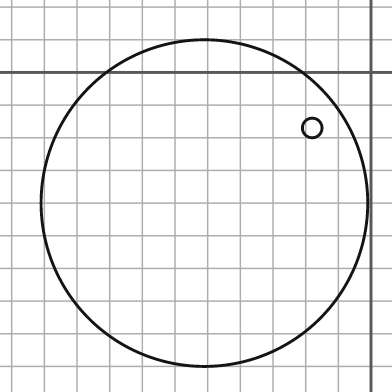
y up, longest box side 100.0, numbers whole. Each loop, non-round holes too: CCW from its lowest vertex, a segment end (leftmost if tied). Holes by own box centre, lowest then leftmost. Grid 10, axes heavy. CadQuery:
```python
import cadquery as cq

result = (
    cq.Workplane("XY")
    .moveTo(-51.0, -40.0)
    .circle(50.0)
    .moveTo(-18.0, -17.0)
    .circle(3.0)
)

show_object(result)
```